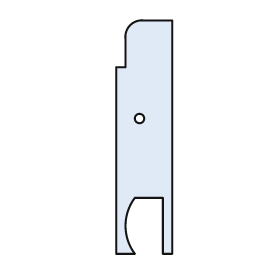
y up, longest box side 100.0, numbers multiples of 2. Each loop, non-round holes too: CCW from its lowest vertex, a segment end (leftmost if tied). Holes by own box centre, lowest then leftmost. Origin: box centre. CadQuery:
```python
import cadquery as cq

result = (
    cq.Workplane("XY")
    .moveTo(-12.0, -50.0)
    .lineTo(-4.0, -50.0)
    .threePointArc((-8.0, -38.0), (-4.0, -26.0))
    .lineTo(8.0, -26.0)
    .lineTo(8.0, -50.0)
    .lineTo(12.0, -50.0)
    .lineTo(12.0, 50.0)
    .lineTo(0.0, 50.0)
    .threePointArc((-6.0, 48.0), (-8.0, 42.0))
    .lineTo(-8.0, 30.0)
    .lineTo(-12.0, 30.0)
    .close()
    .moveTo(-2.0, 8.0)
    .circle(2.0)
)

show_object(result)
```